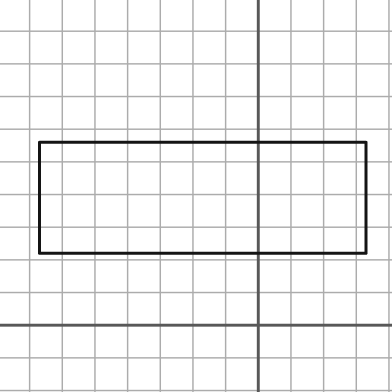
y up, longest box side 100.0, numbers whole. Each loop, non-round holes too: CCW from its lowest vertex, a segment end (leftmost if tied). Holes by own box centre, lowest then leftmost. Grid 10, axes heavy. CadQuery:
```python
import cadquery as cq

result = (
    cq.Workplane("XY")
    .moveTo(-67.0, 22.0)
    .lineTo(33.0, 22.0)
    .lineTo(33.0, 56.0)
    .lineTo(-67.0, 56.0)
    .close()
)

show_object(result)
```